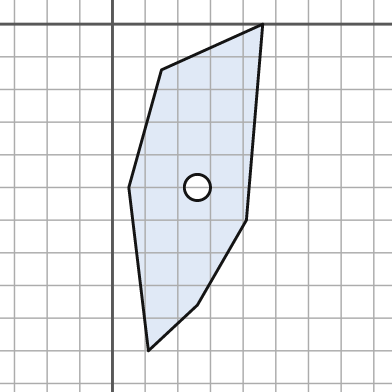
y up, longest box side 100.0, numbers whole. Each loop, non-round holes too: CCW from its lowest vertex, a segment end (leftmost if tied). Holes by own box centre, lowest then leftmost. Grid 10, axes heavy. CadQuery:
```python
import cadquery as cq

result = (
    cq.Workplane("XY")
    .moveTo(11.0, -100.0)
    .lineTo(26.0, -86.0)
    .lineTo(41.0, -60.0)
    .lineTo(46.0, 0.0)
    .lineTo(15.0, -14.0)
    .lineTo(5.0, -50.0)
    .close()
    .moveTo(26.0, -50.0)
    .circle(4.0)
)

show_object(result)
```